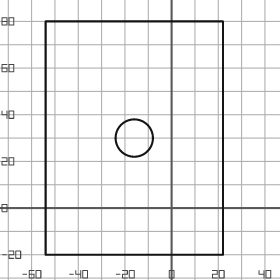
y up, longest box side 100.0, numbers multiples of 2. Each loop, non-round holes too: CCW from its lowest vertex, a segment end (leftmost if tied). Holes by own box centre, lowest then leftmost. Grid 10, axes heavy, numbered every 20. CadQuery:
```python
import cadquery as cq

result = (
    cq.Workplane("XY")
    .moveTo(-54.0, -20.0)
    .lineTo(22.0, -20.0)
    .lineTo(22.0, 80.0)
    .lineTo(-54.0, 80.0)
    .close()
    .moveTo(-16.0, 30.0)
    .circle(8.0)
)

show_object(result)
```